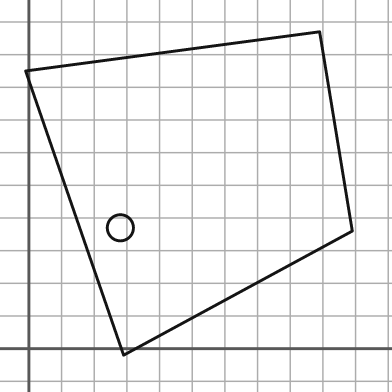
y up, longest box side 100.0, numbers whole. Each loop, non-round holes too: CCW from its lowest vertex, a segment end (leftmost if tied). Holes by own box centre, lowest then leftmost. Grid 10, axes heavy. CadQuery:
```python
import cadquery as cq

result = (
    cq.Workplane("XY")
    .moveTo(29.0, -2.0)
    .lineTo(99.0, 36.0)
    .lineTo(89.0, 97.0)
    .lineTo(-1.0, 85.0)
    .close()
    .moveTo(28.0, 37.0)
    .circle(4.0)
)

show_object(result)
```